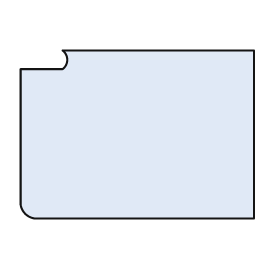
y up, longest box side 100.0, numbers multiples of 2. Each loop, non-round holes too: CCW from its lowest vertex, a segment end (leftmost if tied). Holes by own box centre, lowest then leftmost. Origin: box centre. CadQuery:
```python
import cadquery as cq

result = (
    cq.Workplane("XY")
    .moveTo(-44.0, -36.0)
    .lineTo(50.0, -36.0)
    .lineTo(50.0, 36.0)
    .lineTo(-32.0, 36.0)
    .threePointArc((-30.0, 32.0), (-32.0, 28.0))
    .lineTo(-50.0, 28.0)
    .lineTo(-50.0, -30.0)
    .threePointArc((-48.0, -34.0), (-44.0, -36.0))
    .close()
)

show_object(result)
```